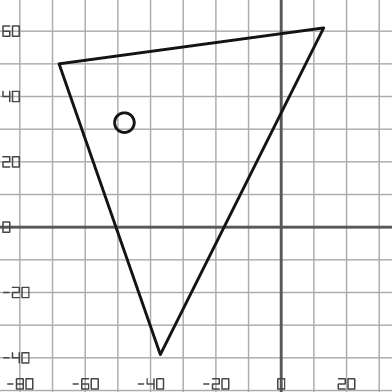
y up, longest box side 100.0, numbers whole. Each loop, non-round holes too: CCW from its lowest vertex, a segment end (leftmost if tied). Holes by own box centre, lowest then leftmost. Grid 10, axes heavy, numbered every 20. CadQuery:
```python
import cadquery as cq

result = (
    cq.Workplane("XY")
    .moveTo(-37.0, -39.0)
    .lineTo(13.0, 61.0)
    .lineTo(-68.0, 50.0)
    .close()
    .moveTo(-48.0, 32.0)
    .circle(3.0)
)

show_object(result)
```